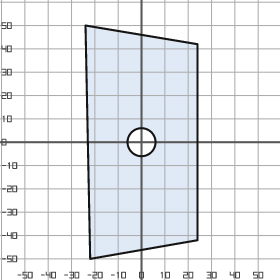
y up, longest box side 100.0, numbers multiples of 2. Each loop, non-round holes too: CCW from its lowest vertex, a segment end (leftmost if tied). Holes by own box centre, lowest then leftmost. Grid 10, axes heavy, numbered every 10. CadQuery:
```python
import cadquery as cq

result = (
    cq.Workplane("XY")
    .moveTo(-22.0, -50.0)
    .lineTo(24.0, -42.0)
    .lineTo(24.0, 42.0)
    .lineTo(-24.0, 50.0)
    .close()
    .moveTo(0.0, 0.0)
    .circle(6.0)
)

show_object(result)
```